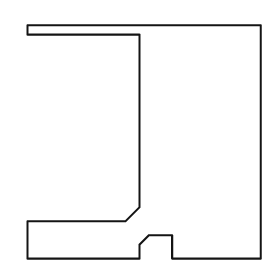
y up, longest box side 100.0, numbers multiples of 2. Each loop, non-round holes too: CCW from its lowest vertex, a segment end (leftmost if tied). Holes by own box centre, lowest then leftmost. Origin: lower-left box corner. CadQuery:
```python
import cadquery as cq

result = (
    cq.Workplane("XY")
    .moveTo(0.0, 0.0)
    .lineTo(48.0, 0.0)
    .lineTo(48.0, 6.0)
    .lineTo(52.0, 10.0)
    .lineTo(62.0, 10.0)
    .lineTo(62.0, 0.0)
    .lineTo(100.0, 0.0)
    .lineTo(100.0, 100.0)
    .lineTo(0.0, 100.0)
    .lineTo(0.0, 96.0)
    .lineTo(48.0, 96.0)
    .lineTo(48.0, 22.0)
    .lineTo(42.0, 16.0)
    .lineTo(0.0, 16.0)
    .close()
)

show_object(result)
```